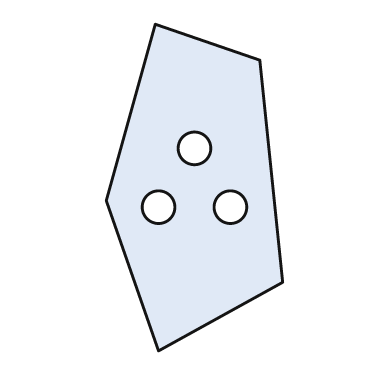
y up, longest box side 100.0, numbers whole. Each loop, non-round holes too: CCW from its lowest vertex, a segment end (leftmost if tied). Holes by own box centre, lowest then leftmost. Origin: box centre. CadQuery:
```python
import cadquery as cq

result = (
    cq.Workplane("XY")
    .moveTo(-11.0, -50.0)
    .lineTo(27.0, -29.0)
    .lineTo(20.0, 39.0)
    .lineTo(-12.0, 50.0)
    .lineTo(-27.0, -4.0)
    .close()
    .moveTo(-11.0, -6.0)
    .circle(5.0)
    .moveTo(11.0, -6.0)
    .circle(5.0)
    .moveTo(0.0, 12.0)
    .circle(5.0)
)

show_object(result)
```